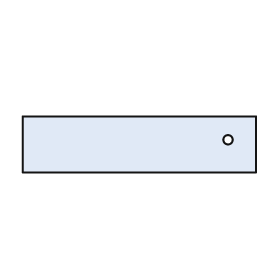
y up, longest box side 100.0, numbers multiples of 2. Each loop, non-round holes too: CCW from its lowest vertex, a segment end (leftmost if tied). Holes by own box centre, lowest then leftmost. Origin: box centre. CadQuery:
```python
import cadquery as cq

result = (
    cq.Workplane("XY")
    .moveTo(-50.0, -12.0)
    .lineTo(50.0, -12.0)
    .lineTo(50.0, 12.0)
    .lineTo(-50.0, 12.0)
    .close()
    .moveTo(38.0, 2.0)
    .circle(2.0)
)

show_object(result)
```